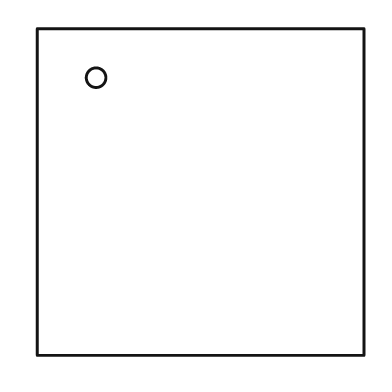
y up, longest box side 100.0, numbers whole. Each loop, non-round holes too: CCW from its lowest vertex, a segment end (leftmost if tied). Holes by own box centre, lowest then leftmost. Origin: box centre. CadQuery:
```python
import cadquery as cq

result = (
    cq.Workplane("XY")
    .moveTo(-50.0, -50.0)
    .lineTo(50.0, -50.0)
    .lineTo(50.0, 50.0)
    .lineTo(-50.0, 50.0)
    .close()
    .moveTo(-32.0, 35.0)
    .circle(3.0)
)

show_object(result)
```